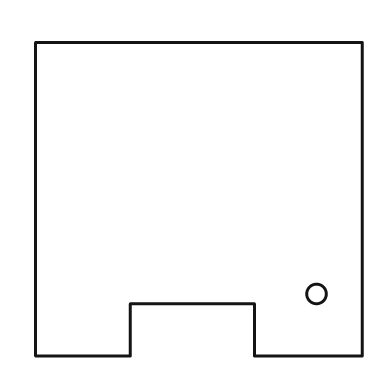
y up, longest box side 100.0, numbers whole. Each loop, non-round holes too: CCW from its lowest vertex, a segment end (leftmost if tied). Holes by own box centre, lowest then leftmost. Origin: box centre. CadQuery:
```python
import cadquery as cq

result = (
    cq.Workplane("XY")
    .moveTo(-50.0, -48.0)
    .lineTo(-21.0, -48.0)
    .lineTo(-21.0, -32.0)
    .lineTo(17.0, -32.0)
    .lineTo(17.0, -48.0)
    .lineTo(50.0, -48.0)
    .lineTo(50.0, 48.0)
    .lineTo(-50.0, 48.0)
    .close()
    .moveTo(36.0, -29.0)
    .circle(3.0)
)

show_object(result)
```